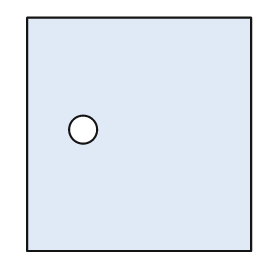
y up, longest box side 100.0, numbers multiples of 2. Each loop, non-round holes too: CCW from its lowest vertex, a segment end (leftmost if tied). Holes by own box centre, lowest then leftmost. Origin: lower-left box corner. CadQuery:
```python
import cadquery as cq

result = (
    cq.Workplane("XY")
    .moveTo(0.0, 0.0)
    .lineTo(96.0, 0.0)
    .lineTo(96.0, 100.0)
    .lineTo(0.0, 100.0)
    .close()
    .moveTo(24.0, 52.0)
    .circle(6.0)
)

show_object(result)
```